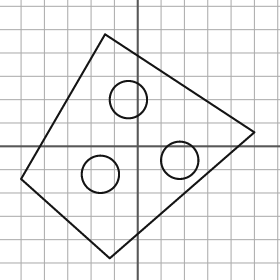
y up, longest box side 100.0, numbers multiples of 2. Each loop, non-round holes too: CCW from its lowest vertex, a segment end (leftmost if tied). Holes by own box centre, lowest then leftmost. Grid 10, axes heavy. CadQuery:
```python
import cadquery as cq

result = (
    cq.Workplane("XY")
    .moveTo(-12.0, -48.0)
    .lineTo(50.0, 6.0)
    .lineTo(-14.0, 48.0)
    .lineTo(-50.0, -14.0)
    .close()
    .moveTo(-16.0, -12.0)
    .circle(8.0)
    .moveTo(18.0, -6.0)
    .circle(8.0)
    .moveTo(-4.0, 20.0)
    .circle(8.0)
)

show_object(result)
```